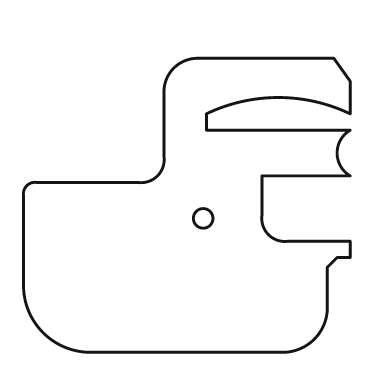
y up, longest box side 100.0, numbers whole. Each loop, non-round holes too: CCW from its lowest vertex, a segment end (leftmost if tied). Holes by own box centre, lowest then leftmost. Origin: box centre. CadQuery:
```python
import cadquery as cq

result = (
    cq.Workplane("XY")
    .moveTo(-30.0, -45.0)
    .lineTo(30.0, -45.0)
    .threePointArc((39.0, -41.0), (43.0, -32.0))
    .lineTo(43.0, -19.0)
    .lineTo(46.0, -16.0)
    .lineTo(50.0, -16.0)
    .lineTo(50.0, -11.0)
    .lineTo(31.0, -11.0)
    .threePointArc((25.0, -9.0), (23.0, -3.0))
    .lineTo(23.0, 9.0)
    .lineTo(50.0, 9.0)
    .threePointArc((46.0, 16.0), (50.0, 23.0))
    .lineTo(6.0, 23.0)
    .lineTo(6.0, 28.0)
    .threePointArc((28.0, 33.0), (50.0, 28.0))
    .lineTo(50.0, 38.0)
    .lineTo(45.0, 45.0)
    .lineTo(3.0, 45.0)
    .threePointArc((-4.0, 42.0), (-7.0, 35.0))
    .lineTo(-7.0, 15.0)
    .threePointArc((-9.0, 9.0), (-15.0, 7.0))
    .lineTo(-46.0, 7.0)
    .threePointArc((-49.0, 6.0), (-50.0, 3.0))
    .lineTo(-50.0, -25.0)
    .threePointArc((-44.0, -39.0), (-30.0, -45.0))
    .close()
    .moveTo(5.0, -4.0)
    .circle(3.0)
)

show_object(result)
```